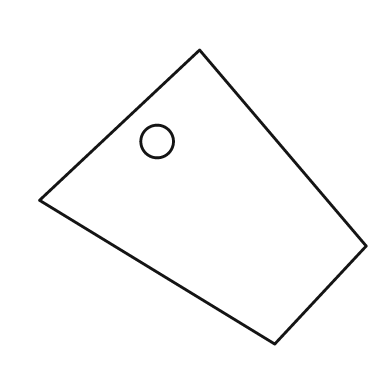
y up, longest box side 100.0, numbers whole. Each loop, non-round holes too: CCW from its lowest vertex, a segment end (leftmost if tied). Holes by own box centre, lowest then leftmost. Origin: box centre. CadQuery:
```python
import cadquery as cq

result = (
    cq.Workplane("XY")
    .moveTo(22.0, -45.0)
    .lineTo(50.0, -15.0)
    .lineTo(-1.0, 45.0)
    .lineTo(-50.0, -1.0)
    .close()
    .moveTo(-14.0, 17.0)
    .circle(5.0)
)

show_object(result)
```